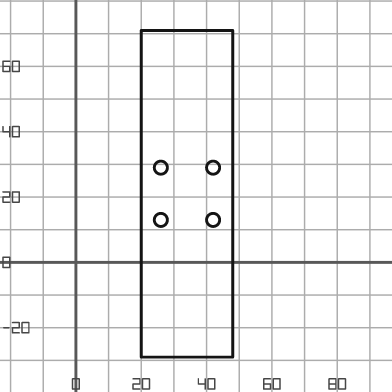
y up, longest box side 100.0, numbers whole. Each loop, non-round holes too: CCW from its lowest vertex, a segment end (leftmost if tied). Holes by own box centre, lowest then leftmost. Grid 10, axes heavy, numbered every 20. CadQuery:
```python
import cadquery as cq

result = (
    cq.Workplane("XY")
    .moveTo(20.0, -29.0)
    .lineTo(48.0, -29.0)
    .lineTo(48.0, 71.0)
    .lineTo(20.0, 71.0)
    .close()
    .moveTo(26.0, 13.0)
    .circle(2.0)
    .moveTo(42.0, 13.0)
    .circle(2.0)
    .moveTo(26.0, 29.0)
    .circle(2.0)
    .moveTo(42.0, 29.0)
    .circle(2.0)
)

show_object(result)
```